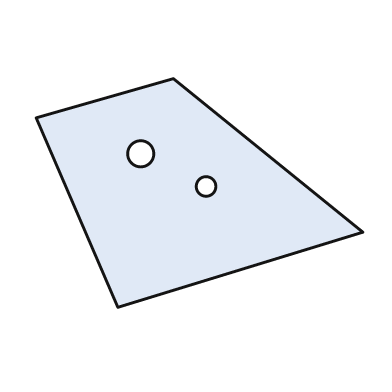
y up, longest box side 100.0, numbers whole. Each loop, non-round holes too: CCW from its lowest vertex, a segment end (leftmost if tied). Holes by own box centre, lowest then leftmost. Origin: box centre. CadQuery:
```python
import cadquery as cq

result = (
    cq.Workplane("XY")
    .moveTo(-25.0, -35.0)
    .lineTo(50.0, -12.0)
    .lineTo(-8.0, 35.0)
    .lineTo(-50.0, 23.0)
    .close()
    .moveTo(2.0, 2.0)
    .circle(3.0)
    .moveTo(-18.0, 12.0)
    .circle(4.0)
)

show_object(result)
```